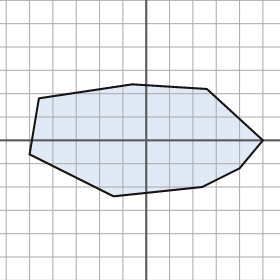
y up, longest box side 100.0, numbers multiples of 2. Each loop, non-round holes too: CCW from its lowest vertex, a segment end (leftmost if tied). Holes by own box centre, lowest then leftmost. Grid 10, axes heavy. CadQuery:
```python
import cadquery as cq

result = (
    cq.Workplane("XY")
    .moveTo(-14.0, -24.0)
    .lineTo(24.0, -20.0)
    .lineTo(40.0, -12.0)
    .lineTo(50.0, 0.0)
    .lineTo(26.0, 22.0)
    .lineTo(-6.0, 24.0)
    .lineTo(-46.0, 18.0)
    .lineTo(-50.0, -6.0)
    .close()
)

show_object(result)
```